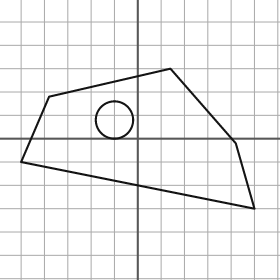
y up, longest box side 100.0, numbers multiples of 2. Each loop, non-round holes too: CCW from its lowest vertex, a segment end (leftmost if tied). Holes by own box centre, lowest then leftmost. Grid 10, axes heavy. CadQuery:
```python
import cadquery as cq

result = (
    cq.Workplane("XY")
    .moveTo(50.0, -30.0)
    .lineTo(42.0, -2.0)
    .lineTo(14.0, 30.0)
    .lineTo(-38.0, 18.0)
    .lineTo(-50.0, -10.0)
    .close()
    .moveTo(-10.0, 8.0)
    .circle(8.0)
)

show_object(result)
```